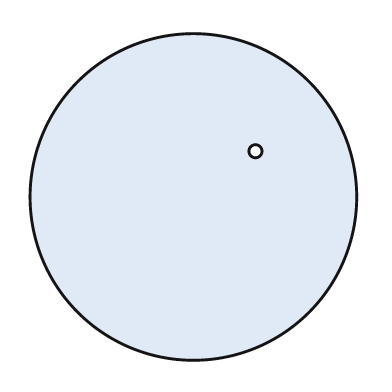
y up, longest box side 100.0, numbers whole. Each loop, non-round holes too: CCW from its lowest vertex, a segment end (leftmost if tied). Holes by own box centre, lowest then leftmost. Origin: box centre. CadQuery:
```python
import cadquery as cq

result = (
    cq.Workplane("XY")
    .moveTo(0.0, 0.0)
    .circle(50.0)
    .moveTo(19.0, 14.0)
    .circle(2.0)
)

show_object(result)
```